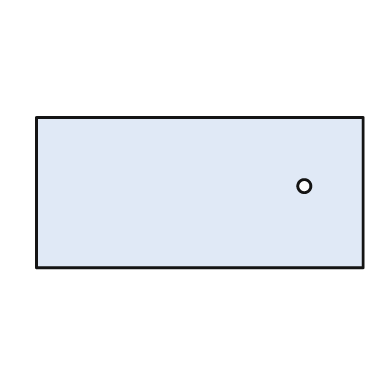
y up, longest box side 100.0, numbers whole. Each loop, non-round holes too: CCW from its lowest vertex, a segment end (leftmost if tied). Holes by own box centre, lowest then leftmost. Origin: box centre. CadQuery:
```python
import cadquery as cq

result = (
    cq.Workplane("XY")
    .moveTo(-50.0, -23.0)
    .lineTo(50.0, -23.0)
    .lineTo(50.0, 23.0)
    .lineTo(-50.0, 23.0)
    .close()
    .moveTo(32.0, 2.0)
    .circle(2.0)
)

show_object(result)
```